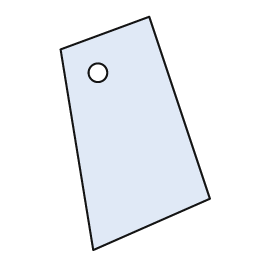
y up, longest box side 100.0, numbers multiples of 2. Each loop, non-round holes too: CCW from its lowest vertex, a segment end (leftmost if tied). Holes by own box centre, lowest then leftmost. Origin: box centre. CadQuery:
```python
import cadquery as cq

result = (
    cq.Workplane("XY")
    .moveTo(-18.0, -50.0)
    .lineTo(32.0, -28.0)
    .lineTo(6.0, 50.0)
    .lineTo(-32.0, 36.0)
    .close()
    .moveTo(-16.0, 26.0)
    .circle(4.0)
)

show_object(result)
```